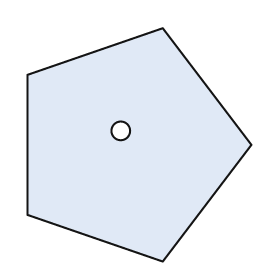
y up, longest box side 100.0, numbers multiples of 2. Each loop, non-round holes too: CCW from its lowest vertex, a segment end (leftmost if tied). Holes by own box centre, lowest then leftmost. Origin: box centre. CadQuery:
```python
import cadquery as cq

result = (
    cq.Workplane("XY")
    .moveTo(10.0, -50.0)
    .lineTo(48.0, 0.0)
    .lineTo(10.0, 50.0)
    .lineTo(-48.0, 30.0)
    .lineTo(-48.0, -30.0)
    .close()
    .moveTo(-8.0, 6.0)
    .circle(4.0)
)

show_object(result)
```